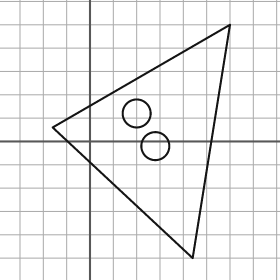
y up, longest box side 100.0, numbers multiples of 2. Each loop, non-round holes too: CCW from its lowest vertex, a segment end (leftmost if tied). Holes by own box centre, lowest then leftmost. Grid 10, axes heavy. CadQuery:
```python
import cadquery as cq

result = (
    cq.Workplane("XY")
    .moveTo(44.0, -50.0)
    .lineTo(60.0, 50.0)
    .lineTo(-16.0, 6.0)
    .close()
    .moveTo(28.0, -2.0)
    .circle(6.0)
    .moveTo(20.0, 12.0)
    .circle(6.0)
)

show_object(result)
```